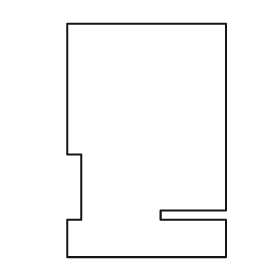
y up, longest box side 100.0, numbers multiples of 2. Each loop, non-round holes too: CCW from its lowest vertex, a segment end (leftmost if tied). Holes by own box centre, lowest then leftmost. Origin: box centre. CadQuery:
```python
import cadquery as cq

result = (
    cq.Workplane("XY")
    .moveTo(-34.0, -50.0)
    .lineTo(34.0, -50.0)
    .lineTo(34.0, -34.0)
    .lineTo(6.0, -34.0)
    .lineTo(6.0, -30.0)
    .lineTo(34.0, -30.0)
    .lineTo(34.0, 50.0)
    .lineTo(-34.0, 50.0)
    .lineTo(-34.0, -6.0)
    .lineTo(-28.0, -6.0)
    .lineTo(-28.0, -34.0)
    .lineTo(-34.0, -34.0)
    .close()
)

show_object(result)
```